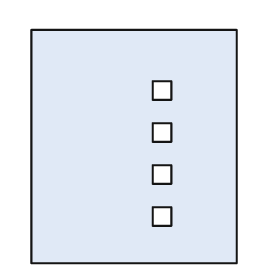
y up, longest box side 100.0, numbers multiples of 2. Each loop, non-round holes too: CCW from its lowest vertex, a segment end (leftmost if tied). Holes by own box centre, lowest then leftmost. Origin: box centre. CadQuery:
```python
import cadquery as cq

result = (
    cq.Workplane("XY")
    .moveTo(-44.0, -50.0)
    .lineTo(44.0, -50.0)
    .lineTo(44.0, 50.0)
    .lineTo(-44.0, 50.0)
    .close()
    .moveTo(8.0, -34.0)
    .lineTo(16.0, -34.0)
    .lineTo(16.0, -26.0)
    .lineTo(8.0, -26.0)
    .close()
    .moveTo(8.0, -16.0)
    .lineTo(16.0, -16.0)
    .lineTo(16.0, -8.0)
    .lineTo(8.0, -8.0)
    .close()
    .moveTo(8.0, 2.0)
    .lineTo(16.0, 2.0)
    .lineTo(16.0, 10.0)
    .lineTo(8.0, 10.0)
    .close()
    .moveTo(8.0, 20.0)
    .lineTo(16.0, 20.0)
    .lineTo(16.0, 28.0)
    .lineTo(8.0, 28.0)
    .close()
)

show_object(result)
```